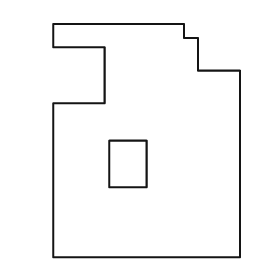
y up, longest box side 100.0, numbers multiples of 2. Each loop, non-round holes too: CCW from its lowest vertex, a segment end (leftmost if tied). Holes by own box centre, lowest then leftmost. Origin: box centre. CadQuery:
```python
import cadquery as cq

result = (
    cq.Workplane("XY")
    .moveTo(-40.0, -50.0)
    .lineTo(40.0, -50.0)
    .lineTo(40.0, 30.0)
    .lineTo(22.0, 30.0)
    .lineTo(22.0, 44.0)
    .lineTo(16.0, 44.0)
    .lineTo(16.0, 50.0)
    .lineTo(-40.0, 50.0)
    .lineTo(-40.0, 40.0)
    .lineTo(-18.0, 40.0)
    .lineTo(-18.0, 16.0)
    .lineTo(-40.0, 16.0)
    .close()
    .moveTo(-16.0, -20.0)
    .lineTo(0.0, -20.0)
    .lineTo(0.0, 0.0)
    .lineTo(-16.0, 0.0)
    .close()
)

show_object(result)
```